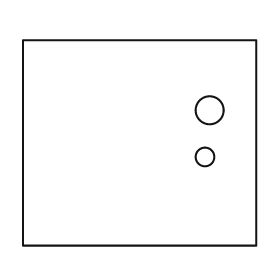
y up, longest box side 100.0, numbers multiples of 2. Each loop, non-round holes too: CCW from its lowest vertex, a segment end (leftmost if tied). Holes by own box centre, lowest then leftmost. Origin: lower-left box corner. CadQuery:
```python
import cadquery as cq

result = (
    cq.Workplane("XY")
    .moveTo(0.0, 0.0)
    .lineTo(100.0, 0.0)
    .lineTo(100.0, 88.0)
    .lineTo(0.0, 88.0)
    .close()
    .moveTo(78.0, 38.0)
    .circle(4.0)
    .moveTo(80.0, 58.0)
    .circle(6.0)
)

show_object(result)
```